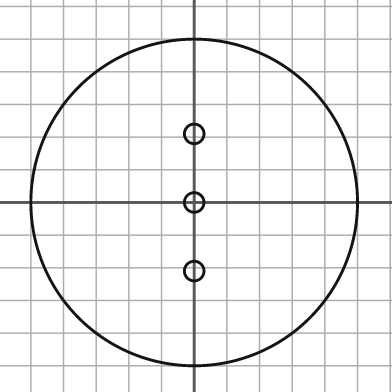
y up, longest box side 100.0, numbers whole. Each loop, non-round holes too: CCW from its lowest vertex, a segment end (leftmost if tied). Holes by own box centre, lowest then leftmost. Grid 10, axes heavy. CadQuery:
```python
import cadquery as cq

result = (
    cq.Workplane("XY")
    .moveTo(0.0, 0.0)
    .circle(50.0)
    .moveTo(0.0, -21.0)
    .circle(3.0)
    .moveTo(0.0, 0.0)
    .circle(3.0)
    .moveTo(0.0, 21.0)
    .circle(3.0)
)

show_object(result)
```